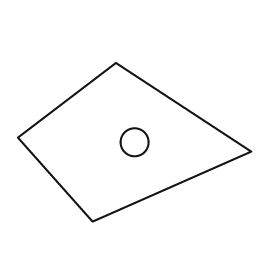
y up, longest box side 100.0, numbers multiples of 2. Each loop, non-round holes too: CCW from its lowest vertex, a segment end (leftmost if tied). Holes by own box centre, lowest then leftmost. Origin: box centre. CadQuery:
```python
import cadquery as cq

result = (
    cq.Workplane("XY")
    .moveTo(-18.0, -34.0)
    .lineTo(50.0, -4.0)
    .lineTo(-8.0, 34.0)
    .lineTo(-50.0, 2.0)
    .close()
    .moveTo(0.0, 0.0)
    .circle(6.0)
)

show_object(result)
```